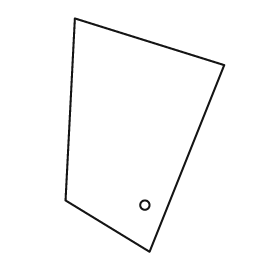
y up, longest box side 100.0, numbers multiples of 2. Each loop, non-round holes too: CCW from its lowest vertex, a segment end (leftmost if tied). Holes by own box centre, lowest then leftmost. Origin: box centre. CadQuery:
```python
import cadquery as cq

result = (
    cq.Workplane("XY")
    .moveTo(2.0, -50.0)
    .lineTo(34.0, 30.0)
    .lineTo(-30.0, 50.0)
    .lineTo(-34.0, -28.0)
    .close()
    .moveTo(0.0, -30.0)
    .circle(2.0)
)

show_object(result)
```